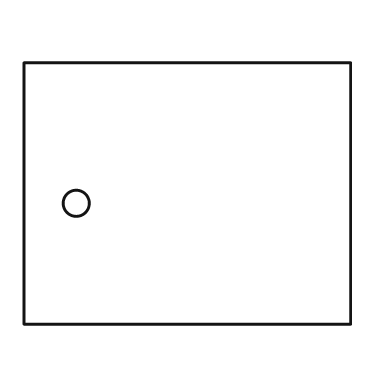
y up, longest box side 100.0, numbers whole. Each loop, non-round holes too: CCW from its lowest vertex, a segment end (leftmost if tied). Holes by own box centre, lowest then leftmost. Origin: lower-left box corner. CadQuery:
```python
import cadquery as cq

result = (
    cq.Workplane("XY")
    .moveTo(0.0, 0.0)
    .lineTo(100.0, 0.0)
    .lineTo(100.0, 80.0)
    .lineTo(0.0, 80.0)
    .close()
    .moveTo(16.0, 37.0)
    .circle(4.0)
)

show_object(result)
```